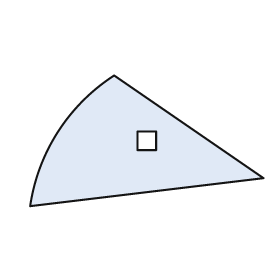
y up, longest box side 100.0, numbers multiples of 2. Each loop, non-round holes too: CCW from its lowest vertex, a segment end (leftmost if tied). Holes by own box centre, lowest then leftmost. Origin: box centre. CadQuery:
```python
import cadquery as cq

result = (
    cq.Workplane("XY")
    .moveTo(-50.0, -28.0)
    .lineTo(50.0, -16.0)
    .lineTo(-14.0, 28.0)
    .threePointArc((-38.0, 4.0), (-50.0, -28.0))
    .close()
    .moveTo(-4.0, -4.0)
    .lineTo(4.0, -4.0)
    .lineTo(4.0, 4.0)
    .lineTo(-4.0, 4.0)
    .close()
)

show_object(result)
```